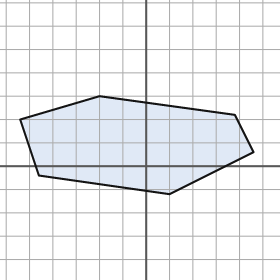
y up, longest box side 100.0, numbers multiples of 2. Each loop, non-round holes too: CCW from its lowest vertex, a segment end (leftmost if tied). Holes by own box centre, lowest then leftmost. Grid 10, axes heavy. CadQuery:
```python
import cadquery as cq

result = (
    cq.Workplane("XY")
    .moveTo(10.0, -12.0)
    .lineTo(46.0, 6.0)
    .lineTo(38.0, 22.0)
    .lineTo(-20.0, 30.0)
    .lineTo(-54.0, 20.0)
    .lineTo(-46.0, -4.0)
    .close()
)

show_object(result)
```